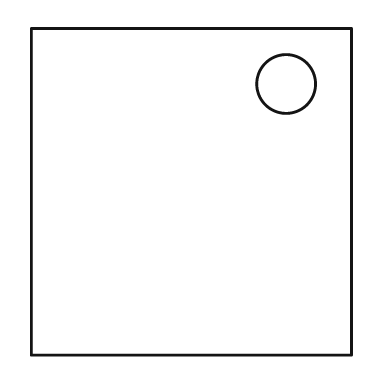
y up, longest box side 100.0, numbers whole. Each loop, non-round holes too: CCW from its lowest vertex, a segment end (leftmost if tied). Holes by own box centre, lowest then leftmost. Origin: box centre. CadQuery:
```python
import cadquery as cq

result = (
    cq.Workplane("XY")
    .moveTo(-49.0, -50.0)
    .lineTo(49.0, -50.0)
    .lineTo(49.0, 50.0)
    .lineTo(-49.0, 50.0)
    .close()
    .moveTo(29.0, 33.0)
    .circle(9.0)
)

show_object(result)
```